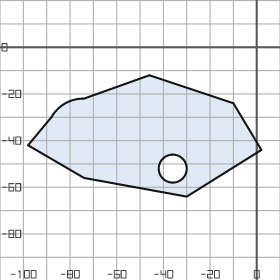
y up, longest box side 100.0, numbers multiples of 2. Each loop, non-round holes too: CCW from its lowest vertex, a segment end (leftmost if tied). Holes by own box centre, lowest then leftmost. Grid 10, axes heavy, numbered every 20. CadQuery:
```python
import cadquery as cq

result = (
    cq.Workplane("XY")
    .moveTo(-30.0, -64.0)
    .lineTo(2.0, -44.0)
    .lineTo(-10.0, -24.0)
    .lineTo(-46.0, -12.0)
    .lineTo(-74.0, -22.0)
    .threePointArc((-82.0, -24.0), (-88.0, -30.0))
    .lineTo(-98.0, -42.0)
    .lineTo(-74.0, -56.0)
    .close()
    .moveTo(-36.0, -52.0)
    .circle(6.0)
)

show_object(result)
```